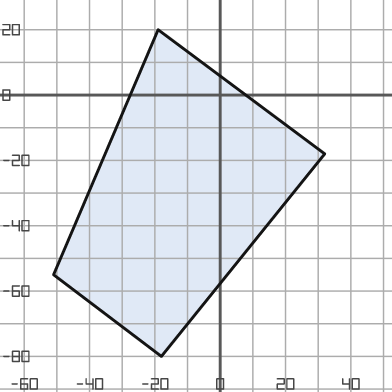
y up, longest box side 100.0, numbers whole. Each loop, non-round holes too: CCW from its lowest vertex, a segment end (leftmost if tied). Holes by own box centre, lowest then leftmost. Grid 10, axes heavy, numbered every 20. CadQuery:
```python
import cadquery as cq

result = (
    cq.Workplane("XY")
    .moveTo(-18.0, -80.0)
    .lineTo(32.0, -18.0)
    .lineTo(-19.0, 20.0)
    .lineTo(-51.0, -55.0)
    .close()
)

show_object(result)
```